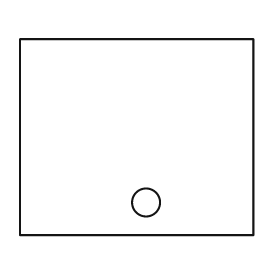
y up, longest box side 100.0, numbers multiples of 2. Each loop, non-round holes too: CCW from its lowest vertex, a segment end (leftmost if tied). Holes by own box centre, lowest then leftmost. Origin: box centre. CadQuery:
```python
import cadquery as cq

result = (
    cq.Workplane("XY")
    .moveTo(-50.0, -42.0)
    .lineTo(50.0, -42.0)
    .lineTo(50.0, 42.0)
    .lineTo(-50.0, 42.0)
    .close()
    .moveTo(4.0, -28.0)
    .circle(6.0)
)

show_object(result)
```